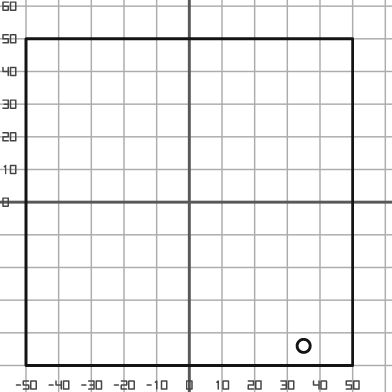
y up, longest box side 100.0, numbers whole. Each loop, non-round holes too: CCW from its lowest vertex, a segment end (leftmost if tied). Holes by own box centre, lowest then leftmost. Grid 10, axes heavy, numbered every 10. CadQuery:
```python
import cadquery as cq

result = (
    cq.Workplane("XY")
    .moveTo(-50.0, -50.0)
    .lineTo(50.0, -50.0)
    .lineTo(50.0, 50.0)
    .lineTo(-50.0, 50.0)
    .close()
    .moveTo(35.0, -44.0)
    .circle(2.0)
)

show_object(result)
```